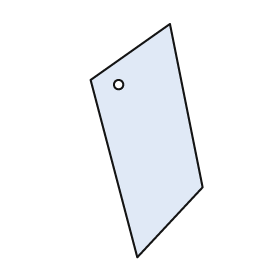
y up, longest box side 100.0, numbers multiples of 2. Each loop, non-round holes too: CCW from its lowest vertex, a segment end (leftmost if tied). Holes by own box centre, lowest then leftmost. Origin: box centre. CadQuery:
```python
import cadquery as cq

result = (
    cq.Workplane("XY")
    .moveTo(-4.0, -50.0)
    .lineTo(24.0, -20.0)
    .lineTo(10.0, 50.0)
    .lineTo(-24.0, 26.0)
    .close()
    .moveTo(-12.0, 24.0)
    .circle(2.0)
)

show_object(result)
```